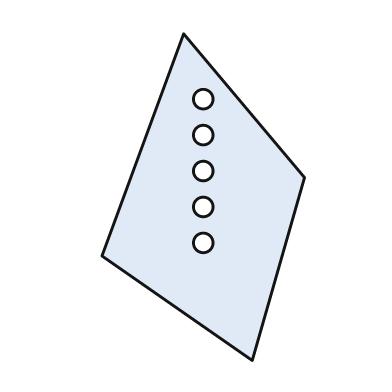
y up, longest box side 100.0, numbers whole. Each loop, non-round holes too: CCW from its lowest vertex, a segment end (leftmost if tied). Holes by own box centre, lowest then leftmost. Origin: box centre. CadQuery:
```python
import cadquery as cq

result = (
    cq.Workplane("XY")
    .moveTo(15.0, -50.0)
    .lineTo(31.0, 6.0)
    .lineTo(-6.0, 50.0)
    .lineTo(-31.0, -18.0)
    .close()
    .moveTo(0.0, -14.0)
    .circle(3.0)
    .moveTo(0.0, -3.0)
    .circle(3.0)
    .moveTo(0.0, 8.0)
    .circle(3.0)
    .moveTo(0.0, 19.0)
    .circle(3.0)
    .moveTo(0.0, 30.0)
    .circle(3.0)
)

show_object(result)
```